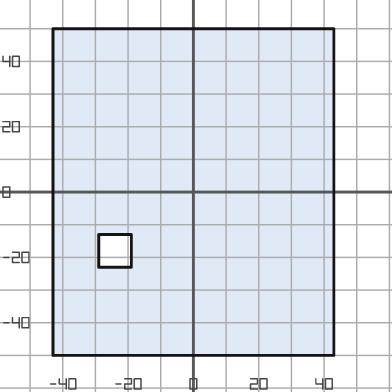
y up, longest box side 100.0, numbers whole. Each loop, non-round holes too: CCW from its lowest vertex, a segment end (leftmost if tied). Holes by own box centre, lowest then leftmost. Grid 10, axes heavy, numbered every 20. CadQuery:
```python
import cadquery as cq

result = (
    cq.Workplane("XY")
    .moveTo(-43.0, -50.0)
    .lineTo(43.0, -50.0)
    .lineTo(43.0, 50.0)
    .lineTo(-43.0, 50.0)
    .close()
    .moveTo(-29.0, -23.0)
    .lineTo(-19.0, -23.0)
    .lineTo(-19.0, -13.0)
    .lineTo(-29.0, -13.0)
    .close()
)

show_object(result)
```